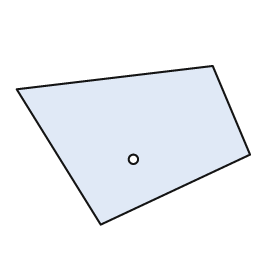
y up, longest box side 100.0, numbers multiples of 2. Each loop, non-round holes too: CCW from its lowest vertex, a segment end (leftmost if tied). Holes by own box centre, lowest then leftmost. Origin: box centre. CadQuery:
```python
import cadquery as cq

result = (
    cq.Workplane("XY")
    .moveTo(-14.0, -34.0)
    .lineTo(50.0, -4.0)
    .lineTo(34.0, 34.0)
    .lineTo(-50.0, 24.0)
    .close()
    .moveTo(0.0, -6.0)
    .circle(2.0)
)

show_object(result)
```